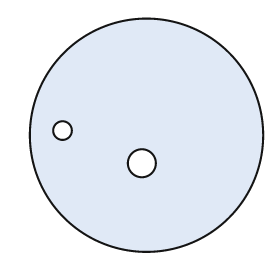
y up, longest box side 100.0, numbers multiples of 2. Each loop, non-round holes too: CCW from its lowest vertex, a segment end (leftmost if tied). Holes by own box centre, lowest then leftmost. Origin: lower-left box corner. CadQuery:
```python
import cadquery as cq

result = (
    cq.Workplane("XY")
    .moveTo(50.0, 50.0)
    .circle(50.0)
    .moveTo(48.0, 38.0)
    .circle(6.0)
    .moveTo(14.0, 52.0)
    .circle(4.0)
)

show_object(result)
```